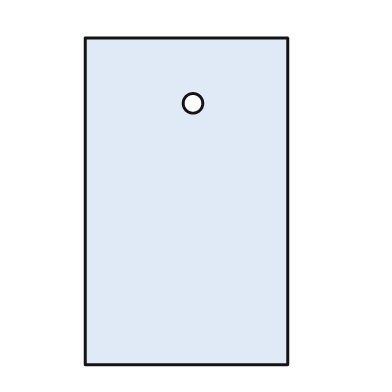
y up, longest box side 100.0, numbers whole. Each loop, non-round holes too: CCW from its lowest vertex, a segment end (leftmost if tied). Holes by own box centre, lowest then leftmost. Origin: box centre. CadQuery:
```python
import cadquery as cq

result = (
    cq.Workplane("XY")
    .moveTo(-31.0, -50.0)
    .lineTo(31.0, -50.0)
    .lineTo(31.0, 50.0)
    .lineTo(-31.0, 50.0)
    .close()
    .moveTo(2.0, 30.0)
    .circle(3.0)
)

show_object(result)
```